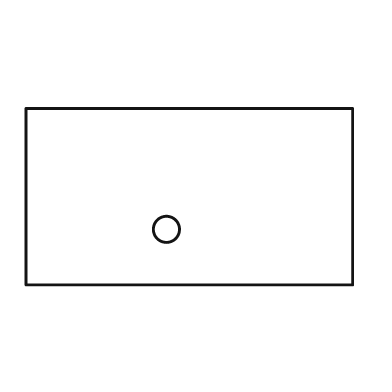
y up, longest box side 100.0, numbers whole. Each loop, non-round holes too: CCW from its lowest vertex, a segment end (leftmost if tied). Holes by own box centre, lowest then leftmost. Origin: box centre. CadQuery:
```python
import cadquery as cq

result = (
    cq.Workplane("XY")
    .moveTo(-50.0, -27.0)
    .lineTo(50.0, -27.0)
    .lineTo(50.0, 27.0)
    .lineTo(-50.0, 27.0)
    .close()
    .moveTo(-7.0, -10.0)
    .circle(4.0)
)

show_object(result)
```